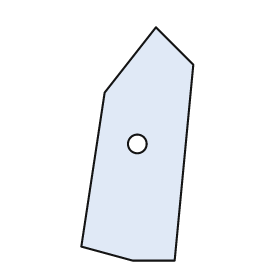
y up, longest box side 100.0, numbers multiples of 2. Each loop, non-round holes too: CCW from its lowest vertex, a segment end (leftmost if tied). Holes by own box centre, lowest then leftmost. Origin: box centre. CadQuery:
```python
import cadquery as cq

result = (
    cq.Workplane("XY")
    .moveTo(-2.0, -50.0)
    .lineTo(16.0, -50.0)
    .lineTo(24.0, 34.0)
    .lineTo(8.0, 50.0)
    .lineTo(-14.0, 22.0)
    .lineTo(-24.0, -44.0)
    .close()
    .moveTo(0.0, 0.0)
    .circle(4.0)
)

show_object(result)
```